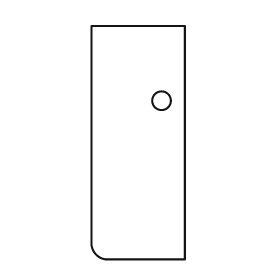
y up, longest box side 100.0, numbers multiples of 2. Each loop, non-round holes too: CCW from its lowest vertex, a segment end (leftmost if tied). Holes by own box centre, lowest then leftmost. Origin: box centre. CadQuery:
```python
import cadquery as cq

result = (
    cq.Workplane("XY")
    .moveTo(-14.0, -50.0)
    .lineTo(20.0, -50.0)
    .lineTo(20.0, 50.0)
    .lineTo(-20.0, 50.0)
    .lineTo(-20.0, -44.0)
    .threePointArc((-18.0, -48.0), (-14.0, -50.0))
    .close()
    .moveTo(10.0, 18.0)
    .circle(4.0)
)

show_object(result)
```